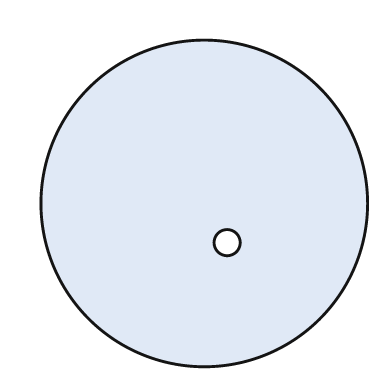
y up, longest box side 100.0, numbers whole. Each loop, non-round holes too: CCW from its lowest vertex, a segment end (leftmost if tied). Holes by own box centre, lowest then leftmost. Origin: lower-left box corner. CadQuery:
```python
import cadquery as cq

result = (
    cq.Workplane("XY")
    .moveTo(50.0, 50.0)
    .circle(50.0)
    .moveTo(57.0, 38.0)
    .circle(4.0)
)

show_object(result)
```